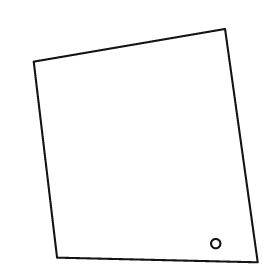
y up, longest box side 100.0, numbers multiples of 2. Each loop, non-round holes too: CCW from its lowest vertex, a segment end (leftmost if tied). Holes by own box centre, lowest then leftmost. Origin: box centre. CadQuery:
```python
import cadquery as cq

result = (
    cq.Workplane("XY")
    .moveTo(48.0, -50.0)
    .lineTo(34.0, 50.0)
    .lineTo(-48.0, 36.0)
    .lineTo(-38.0, -48.0)
    .close()
    .moveTo(30.0, -42.0)
    .circle(2.0)
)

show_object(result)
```